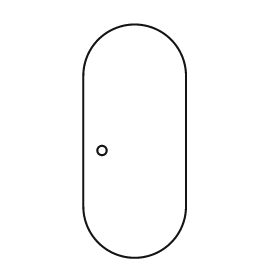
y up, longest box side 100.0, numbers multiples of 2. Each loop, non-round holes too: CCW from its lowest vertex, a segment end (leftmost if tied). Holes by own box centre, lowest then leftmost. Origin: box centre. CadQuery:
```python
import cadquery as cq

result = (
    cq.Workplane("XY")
    .moveTo(-22.0, -28.0)
    .threePointArc((0.0, -50.0), (22.0, -28.0))
    .lineTo(22.0, 28.0)
    .threePointArc((0.0, 50.0), (-22.0, 28.0))
    .close()
    .moveTo(-14.0, -4.0)
    .circle(2.0)
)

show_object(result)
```